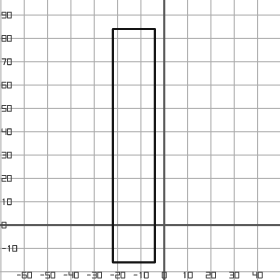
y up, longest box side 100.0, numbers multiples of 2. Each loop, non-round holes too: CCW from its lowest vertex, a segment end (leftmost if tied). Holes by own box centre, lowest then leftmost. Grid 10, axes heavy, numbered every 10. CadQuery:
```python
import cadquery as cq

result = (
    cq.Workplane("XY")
    .moveTo(-22.0, -16.0)
    .lineTo(-4.0, -16.0)
    .lineTo(-4.0, 84.0)
    .lineTo(-22.0, 84.0)
    .close()
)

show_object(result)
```